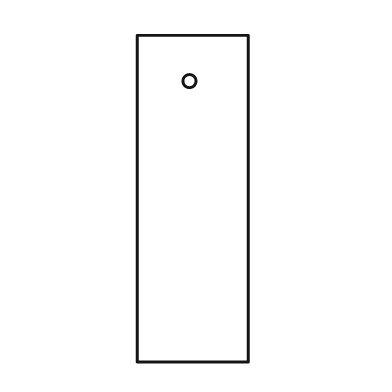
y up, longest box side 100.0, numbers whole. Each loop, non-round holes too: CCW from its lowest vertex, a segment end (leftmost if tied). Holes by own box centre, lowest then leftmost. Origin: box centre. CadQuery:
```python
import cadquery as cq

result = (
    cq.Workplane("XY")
    .moveTo(-17.0, -50.0)
    .lineTo(17.0, -50.0)
    .lineTo(17.0, 50.0)
    .lineTo(-17.0, 50.0)
    .close()
    .moveTo(-1.0, 36.0)
    .circle(2.0)
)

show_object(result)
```